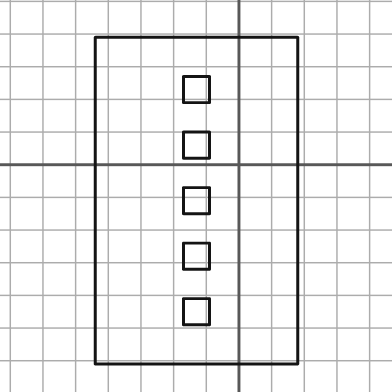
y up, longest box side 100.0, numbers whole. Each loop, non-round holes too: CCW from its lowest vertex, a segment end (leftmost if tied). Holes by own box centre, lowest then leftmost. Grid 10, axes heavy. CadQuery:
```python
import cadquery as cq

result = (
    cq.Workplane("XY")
    .moveTo(-44.0, -61.0)
    .lineTo(18.0, -61.0)
    .lineTo(18.0, 39.0)
    .lineTo(-44.0, 39.0)
    .close()
    .moveTo(-17.0, -49.0)
    .lineTo(-9.0, -49.0)
    .lineTo(-9.0, -41.0)
    .lineTo(-17.0, -41.0)
    .close()
    .moveTo(-17.0, -32.0)
    .lineTo(-9.0, -32.0)
    .lineTo(-9.0, -24.0)
    .lineTo(-17.0, -24.0)
    .close()
    .moveTo(-17.0, -15.0)
    .lineTo(-9.0, -15.0)
    .lineTo(-9.0, -7.0)
    .lineTo(-17.0, -7.0)
    .close()
    .moveTo(-17.0, 2.0)
    .lineTo(-9.0, 2.0)
    .lineTo(-9.0, 10.0)
    .lineTo(-17.0, 10.0)
    .close()
    .moveTo(-17.0, 19.0)
    .lineTo(-9.0, 19.0)
    .lineTo(-9.0, 27.0)
    .lineTo(-17.0, 27.0)
    .close()
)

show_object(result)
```